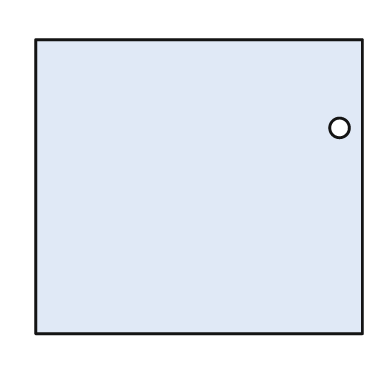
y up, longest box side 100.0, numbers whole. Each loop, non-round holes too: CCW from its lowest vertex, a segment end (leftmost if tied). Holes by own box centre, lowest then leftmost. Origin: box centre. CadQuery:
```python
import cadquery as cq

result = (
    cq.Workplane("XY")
    .moveTo(-50.0, -45.0)
    .lineTo(50.0, -45.0)
    .lineTo(50.0, 45.0)
    .lineTo(-50.0, 45.0)
    .close()
    .moveTo(43.0, 18.0)
    .circle(3.0)
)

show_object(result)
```